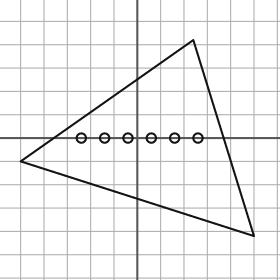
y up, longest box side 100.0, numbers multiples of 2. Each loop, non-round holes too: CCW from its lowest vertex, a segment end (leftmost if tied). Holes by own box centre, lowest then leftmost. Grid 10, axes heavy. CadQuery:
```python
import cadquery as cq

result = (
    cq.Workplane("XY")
    .moveTo(50.0, -42.0)
    .lineTo(24.0, 42.0)
    .lineTo(-50.0, -10.0)
    .close()
    .moveTo(-24.0, 0.0)
    .circle(2.0)
    .moveTo(-14.0, 0.0)
    .circle(2.0)
    .moveTo(-4.0, 0.0)
    .circle(2.0)
    .moveTo(6.0, 0.0)
    .circle(2.0)
    .moveTo(16.0, 0.0)
    .circle(2.0)
    .moveTo(26.0, 0.0)
    .circle(2.0)
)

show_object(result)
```